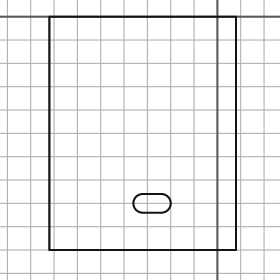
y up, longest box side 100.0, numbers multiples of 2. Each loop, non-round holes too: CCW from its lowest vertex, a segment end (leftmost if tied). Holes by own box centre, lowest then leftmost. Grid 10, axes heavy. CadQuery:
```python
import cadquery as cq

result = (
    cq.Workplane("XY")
    .moveTo(-72.0, -100.0)
    .lineTo(8.0, -100.0)
    .lineTo(8.0, 0.0)
    .lineTo(-72.0, 0.0)
    .close()
    .moveTo(-32.0, -84.0)
    .lineTo(-24.0, -84.0)
    .threePointArc((-20.0, -80.0), (-24.0, -76.0))
    .lineTo(-32.0, -76.0)
    .threePointArc((-36.0, -80.0), (-32.0, -84.0))
    .close()
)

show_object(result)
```